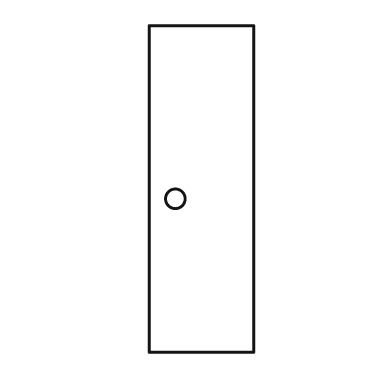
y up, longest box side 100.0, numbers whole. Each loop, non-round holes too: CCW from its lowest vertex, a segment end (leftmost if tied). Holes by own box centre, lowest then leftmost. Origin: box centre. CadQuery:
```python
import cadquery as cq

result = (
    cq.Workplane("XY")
    .moveTo(-16.0, -50.0)
    .lineTo(16.0, -50.0)
    .lineTo(16.0, 50.0)
    .lineTo(-16.0, 50.0)
    .close()
    .moveTo(-8.0, -3.0)
    .circle(3.0)
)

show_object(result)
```